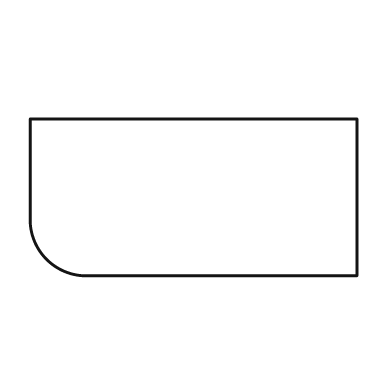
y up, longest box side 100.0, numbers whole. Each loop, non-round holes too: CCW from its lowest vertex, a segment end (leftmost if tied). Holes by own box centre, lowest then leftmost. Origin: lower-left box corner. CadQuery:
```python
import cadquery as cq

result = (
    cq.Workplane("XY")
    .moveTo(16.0, 0.0)
    .lineTo(100.0, 0.0)
    .lineTo(100.0, 48.0)
    .lineTo(0.0, 48.0)
    .lineTo(0.0, 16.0)
    .threePointArc((5.0, 5.0), (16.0, 0.0))
    .close()
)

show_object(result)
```